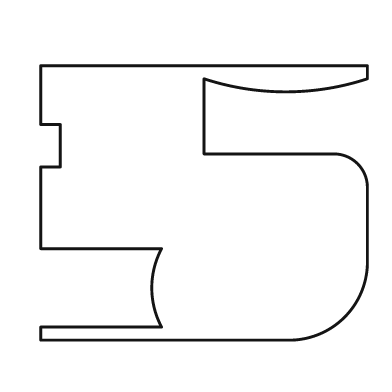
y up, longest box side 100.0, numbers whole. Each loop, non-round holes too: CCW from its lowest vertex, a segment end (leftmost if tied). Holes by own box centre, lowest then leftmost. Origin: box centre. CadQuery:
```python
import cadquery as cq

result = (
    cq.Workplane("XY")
    .moveTo(-50.0, -42.0)
    .lineTo(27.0, -42.0)
    .threePointArc((43.0, -35.0), (50.0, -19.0))
    .lineTo(50.0, 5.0)
    .threePointArc((47.0, 12.0), (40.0, 15.0))
    .lineTo(0.0, 15.0)
    .lineTo(0.0, 38.0)
    .threePointArc((25.0, 34.0), (50.0, 38.0))
    .lineTo(50.0, 42.0)
    .lineTo(-50.0, 42.0)
    .lineTo(-50.0, 24.0)
    .lineTo(-44.0, 24.0)
    .lineTo(-44.0, 11.0)
    .lineTo(-50.0, 11.0)
    .lineTo(-50.0, -14.0)
    .lineTo(-13.0, -14.0)
    .threePointArc((-16.0, -26.0), (-13.0, -38.0))
    .lineTo(-50.0, -38.0)
    .close()
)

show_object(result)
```